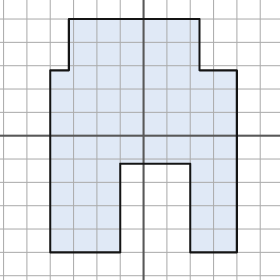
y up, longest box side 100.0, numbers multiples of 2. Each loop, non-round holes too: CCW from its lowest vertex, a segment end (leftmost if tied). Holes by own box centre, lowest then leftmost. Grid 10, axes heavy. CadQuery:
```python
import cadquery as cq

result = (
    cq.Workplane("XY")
    .moveTo(-40.0, -50.0)
    .lineTo(-10.0, -50.0)
    .lineTo(-10.0, -12.0)
    .lineTo(20.0, -12.0)
    .lineTo(20.0, -50.0)
    .lineTo(40.0, -50.0)
    .lineTo(40.0, 28.0)
    .lineTo(24.0, 28.0)
    .lineTo(24.0, 50.0)
    .lineTo(-32.0, 50.0)
    .lineTo(-32.0, 28.0)
    .lineTo(-40.0, 28.0)
    .close()
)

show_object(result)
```